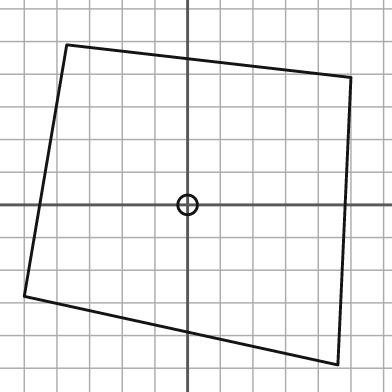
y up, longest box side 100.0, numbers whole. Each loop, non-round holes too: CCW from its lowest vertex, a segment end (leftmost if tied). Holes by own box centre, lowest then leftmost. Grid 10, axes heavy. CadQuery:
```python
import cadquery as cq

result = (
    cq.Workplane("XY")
    .moveTo(46.0, -49.0)
    .lineTo(50.0, 39.0)
    .lineTo(-37.0, 49.0)
    .lineTo(-50.0, -28.0)
    .close()
    .moveTo(0.0, 0.0)
    .circle(3.0)
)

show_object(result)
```